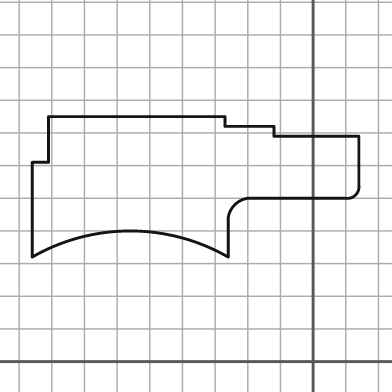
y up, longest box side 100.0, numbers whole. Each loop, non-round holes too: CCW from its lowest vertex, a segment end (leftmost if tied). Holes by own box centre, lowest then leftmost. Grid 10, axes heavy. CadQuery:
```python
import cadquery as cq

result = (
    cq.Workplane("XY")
    .moveTo(-86.0, 32.0)
    .threePointArc((-56.0, 40.0), (-26.0, 32.0))
    .lineTo(-26.0, 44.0)
    .threePointArc((-24.0, 48.0), (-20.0, 50.0))
    .lineTo(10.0, 50.0)
    .threePointArc((13.0, 51.0), (14.0, 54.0))
    .lineTo(14.0, 69.0)
    .lineTo(-12.0, 69.0)
    .lineTo(-12.0, 72.0)
    .lineTo(-27.0, 72.0)
    .lineTo(-27.0, 75.0)
    .lineTo(-81.0, 75.0)
    .lineTo(-81.0, 61.0)
    .lineTo(-86.0, 61.0)
    .close()
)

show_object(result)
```